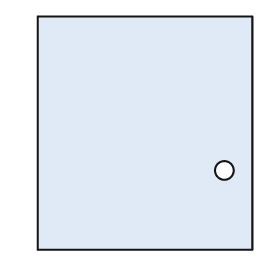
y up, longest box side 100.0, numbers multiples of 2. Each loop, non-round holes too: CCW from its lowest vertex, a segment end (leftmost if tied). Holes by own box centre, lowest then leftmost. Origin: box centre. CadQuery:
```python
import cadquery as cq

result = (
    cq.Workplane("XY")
    .moveTo(-46.0, -50.0)
    .lineTo(46.0, -50.0)
    .lineTo(46.0, 50.0)
    .lineTo(-46.0, 50.0)
    .close()
    .moveTo(34.0, -16.0)
    .circle(4.0)
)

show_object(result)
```